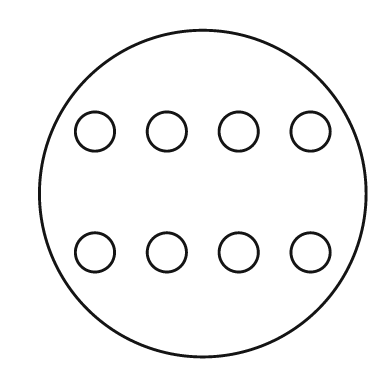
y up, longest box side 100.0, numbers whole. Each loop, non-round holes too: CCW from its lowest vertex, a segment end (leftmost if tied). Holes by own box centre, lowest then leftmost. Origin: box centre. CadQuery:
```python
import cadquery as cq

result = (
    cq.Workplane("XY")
    .moveTo(0.0, 0.0)
    .circle(50.0)
    .moveTo(-33.0, -18.0)
    .circle(6.0)
    .moveTo(-11.0, -18.0)
    .circle(6.0)
    .moveTo(11.0, -18.0)
    .circle(6.0)
    .moveTo(33.0, -18.0)
    .circle(6.0)
    .moveTo(-33.0, 19.0)
    .circle(6.0)
    .moveTo(-11.0, 19.0)
    .circle(6.0)
    .moveTo(11.0, 19.0)
    .circle(6.0)
    .moveTo(33.0, 19.0)
    .circle(6.0)
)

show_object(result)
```